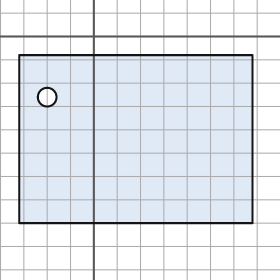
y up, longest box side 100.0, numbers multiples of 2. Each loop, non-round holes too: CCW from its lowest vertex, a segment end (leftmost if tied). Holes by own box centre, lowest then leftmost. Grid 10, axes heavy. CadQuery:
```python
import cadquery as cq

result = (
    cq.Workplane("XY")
    .moveTo(-32.0, -80.0)
    .lineTo(68.0, -80.0)
    .lineTo(68.0, -8.0)
    .lineTo(-32.0, -8.0)
    .close()
    .moveTo(-20.0, -26.0)
    .circle(4.0)
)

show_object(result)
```